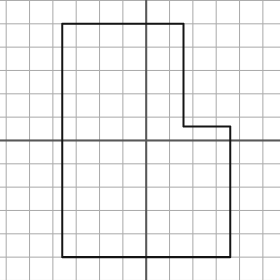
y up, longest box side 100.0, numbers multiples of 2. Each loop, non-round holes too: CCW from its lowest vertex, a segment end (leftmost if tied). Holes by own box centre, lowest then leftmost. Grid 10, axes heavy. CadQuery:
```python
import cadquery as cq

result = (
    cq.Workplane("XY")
    .moveTo(-36.0, -50.0)
    .lineTo(36.0, -50.0)
    .lineTo(36.0, 6.0)
    .lineTo(16.0, 6.0)
    .lineTo(16.0, 50.0)
    .lineTo(-36.0, 50.0)
    .close()
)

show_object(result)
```